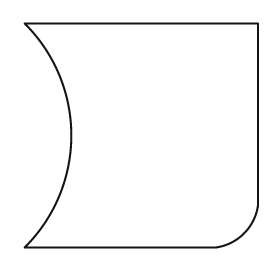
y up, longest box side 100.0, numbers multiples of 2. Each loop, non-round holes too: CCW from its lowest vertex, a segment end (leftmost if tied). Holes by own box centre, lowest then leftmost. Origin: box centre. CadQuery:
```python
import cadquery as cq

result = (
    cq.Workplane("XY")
    .moveTo(-50.0, -48.0)
    .lineTo(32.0, -48.0)
    .threePointArc((44.0, -42.0), (50.0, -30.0))
    .lineTo(50.0, 48.0)
    .lineTo(-50.0, 48.0)
    .threePointArc((-30.0, 0.0), (-50.0, -48.0))
    .close()
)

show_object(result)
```